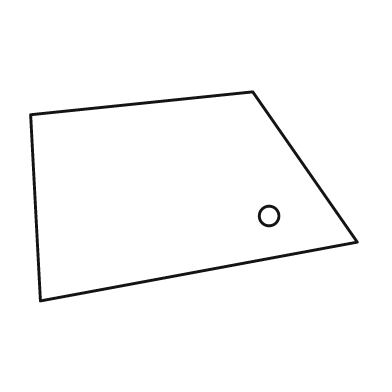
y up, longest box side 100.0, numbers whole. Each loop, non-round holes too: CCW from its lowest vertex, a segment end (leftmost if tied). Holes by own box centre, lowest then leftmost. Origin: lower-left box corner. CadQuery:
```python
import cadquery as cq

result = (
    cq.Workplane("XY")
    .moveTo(3.0, 0.0)
    .lineTo(100.0, 18.0)
    .lineTo(68.0, 64.0)
    .lineTo(0.0, 57.0)
    .close()
    .moveTo(73.0, 26.0)
    .circle(3.0)
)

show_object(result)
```